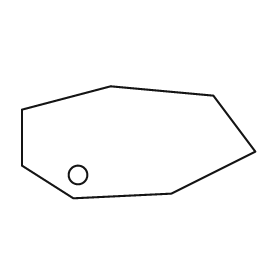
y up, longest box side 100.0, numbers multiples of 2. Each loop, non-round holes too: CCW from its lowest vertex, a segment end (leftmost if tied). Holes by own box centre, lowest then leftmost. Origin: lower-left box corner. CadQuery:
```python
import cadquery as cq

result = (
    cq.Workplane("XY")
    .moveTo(22.0, 0.0)
    .lineTo(64.0, 2.0)
    .lineTo(100.0, 20.0)
    .lineTo(82.0, 44.0)
    .lineTo(38.0, 48.0)
    .lineTo(0.0, 38.0)
    .lineTo(0.0, 14.0)
    .close()
    .moveTo(24.0, 10.0)
    .circle(4.0)
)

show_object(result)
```